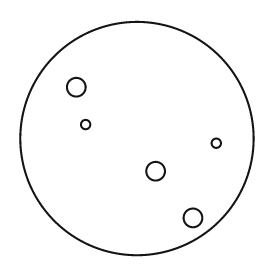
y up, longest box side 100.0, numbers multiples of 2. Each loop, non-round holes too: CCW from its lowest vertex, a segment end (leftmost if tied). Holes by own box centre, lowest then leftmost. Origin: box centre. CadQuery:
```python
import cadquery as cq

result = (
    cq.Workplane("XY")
    .moveTo(0.0, 0.0)
    .circle(50.0)
    .moveTo(24.0, -34.0)
    .circle(4.0)
    .moveTo(8.0, -14.0)
    .circle(4.0)
    .moveTo(34.0, -2.0)
    .circle(2.0)
    .moveTo(-22.0, 6.0)
    .circle(2.0)
    .moveTo(-26.0, 22.0)
    .circle(4.0)
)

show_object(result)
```